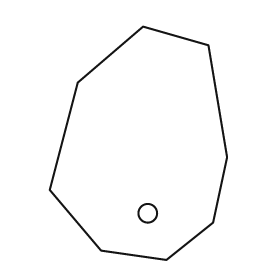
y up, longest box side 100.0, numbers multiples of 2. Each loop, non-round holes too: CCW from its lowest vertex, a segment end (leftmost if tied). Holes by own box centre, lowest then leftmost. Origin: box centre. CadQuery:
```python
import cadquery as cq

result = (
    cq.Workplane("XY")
    .moveTo(12.0, -50.0)
    .lineTo(32.0, -34.0)
    .lineTo(38.0, -6.0)
    .lineTo(30.0, 42.0)
    .lineTo(2.0, 50.0)
    .lineTo(-26.0, 26.0)
    .lineTo(-38.0, -20.0)
    .lineTo(-16.0, -46.0)
    .close()
    .moveTo(4.0, -30.0)
    .circle(4.0)
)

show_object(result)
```